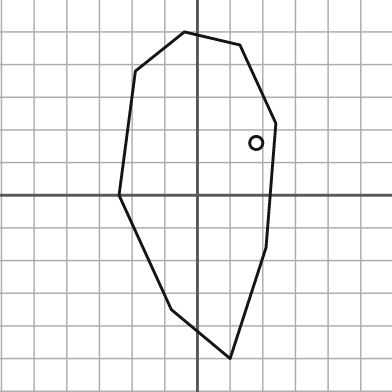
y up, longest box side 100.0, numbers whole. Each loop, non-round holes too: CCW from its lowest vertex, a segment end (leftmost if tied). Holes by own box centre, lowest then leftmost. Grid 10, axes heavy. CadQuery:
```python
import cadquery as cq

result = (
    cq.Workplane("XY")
    .moveTo(10.0, -50.0)
    .lineTo(21.0, -16.0)
    .lineTo(24.0, 22.0)
    .lineTo(13.0, 46.0)
    .lineTo(-4.0, 50.0)
    .lineTo(-19.0, 38.0)
    .lineTo(-24.0, 0.0)
    .lineTo(-8.0, -35.0)
    .close()
    .moveTo(18.0, 16.0)
    .circle(2.0)
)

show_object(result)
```